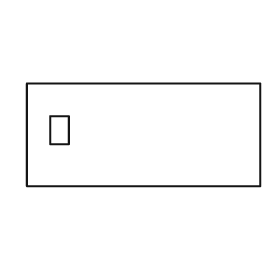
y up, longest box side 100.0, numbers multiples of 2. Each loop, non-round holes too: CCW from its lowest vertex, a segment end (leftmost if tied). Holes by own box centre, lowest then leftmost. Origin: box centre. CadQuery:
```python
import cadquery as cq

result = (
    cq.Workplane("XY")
    .moveTo(-50.0, -22.0)
    .lineTo(50.0, -22.0)
    .lineTo(50.0, 22.0)
    .lineTo(-50.0, 22.0)
    .close()
    .moveTo(-40.0, -4.0)
    .lineTo(-32.0, -4.0)
    .lineTo(-32.0, 8.0)
    .lineTo(-40.0, 8.0)
    .close()
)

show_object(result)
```